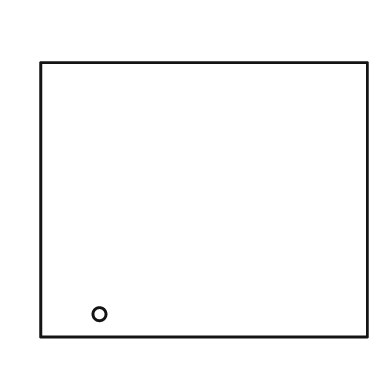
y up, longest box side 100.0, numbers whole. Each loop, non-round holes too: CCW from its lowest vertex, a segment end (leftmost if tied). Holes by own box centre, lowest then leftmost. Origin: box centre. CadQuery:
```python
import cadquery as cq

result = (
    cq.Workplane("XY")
    .moveTo(-50.0, -42.0)
    .lineTo(50.0, -42.0)
    .lineTo(50.0, 42.0)
    .lineTo(-50.0, 42.0)
    .close()
    .moveTo(-32.0, -35.0)
    .circle(2.0)
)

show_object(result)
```